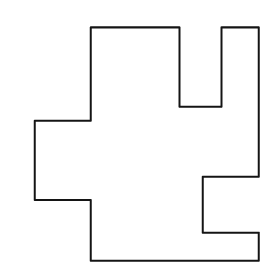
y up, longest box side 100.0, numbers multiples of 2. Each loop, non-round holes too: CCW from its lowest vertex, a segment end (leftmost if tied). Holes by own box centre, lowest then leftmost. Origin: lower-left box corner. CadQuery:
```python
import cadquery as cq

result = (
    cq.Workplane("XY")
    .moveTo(24.0, 0.0)
    .lineTo(96.0, 0.0)
    .lineTo(96.0, 12.0)
    .lineTo(72.0, 12.0)
    .lineTo(72.0, 36.0)
    .lineTo(96.0, 36.0)
    .lineTo(96.0, 100.0)
    .lineTo(80.0, 100.0)
    .lineTo(80.0, 66.0)
    .lineTo(62.0, 66.0)
    .lineTo(62.0, 100.0)
    .lineTo(24.0, 100.0)
    .lineTo(24.0, 60.0)
    .lineTo(0.0, 60.0)
    .lineTo(0.0, 26.0)
    .lineTo(24.0, 26.0)
    .close()
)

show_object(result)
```